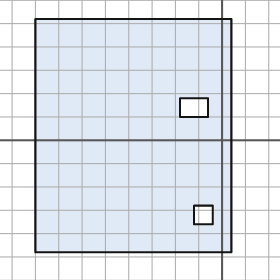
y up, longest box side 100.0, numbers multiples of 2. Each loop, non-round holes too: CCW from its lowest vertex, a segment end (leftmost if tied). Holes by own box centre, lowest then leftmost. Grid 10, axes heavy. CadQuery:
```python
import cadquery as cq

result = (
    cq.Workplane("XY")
    .moveTo(-80.0, -48.0)
    .lineTo(4.0, -48.0)
    .lineTo(4.0, 52.0)
    .lineTo(-80.0, 52.0)
    .close()
    .moveTo(-12.0, -36.0)
    .lineTo(-4.0, -36.0)
    .lineTo(-4.0, -28.0)
    .lineTo(-12.0, -28.0)
    .close()
    .moveTo(-18.0, 10.0)
    .lineTo(-6.0, 10.0)
    .lineTo(-6.0, 18.0)
    .lineTo(-18.0, 18.0)
    .close()
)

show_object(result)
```